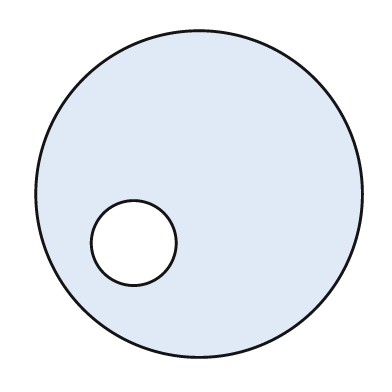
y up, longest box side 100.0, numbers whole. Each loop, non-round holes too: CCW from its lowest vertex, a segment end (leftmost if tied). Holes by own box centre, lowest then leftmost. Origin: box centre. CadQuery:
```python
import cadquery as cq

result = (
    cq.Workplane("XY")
    .moveTo(0.0, 0.0)
    .circle(50.0)
    .moveTo(-20.0, -15.0)
    .circle(13.0)
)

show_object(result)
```